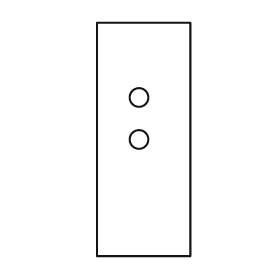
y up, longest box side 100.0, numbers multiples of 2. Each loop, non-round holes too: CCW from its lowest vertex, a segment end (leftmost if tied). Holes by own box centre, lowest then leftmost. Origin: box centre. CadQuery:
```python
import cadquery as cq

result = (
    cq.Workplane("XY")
    .moveTo(-20.0, -50.0)
    .lineTo(20.0, -50.0)
    .lineTo(20.0, 50.0)
    .lineTo(-20.0, 50.0)
    .close()
    .moveTo(-2.0, 0.0)
    .circle(4.0)
    .moveTo(-2.0, 18.0)
    .circle(4.0)
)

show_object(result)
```